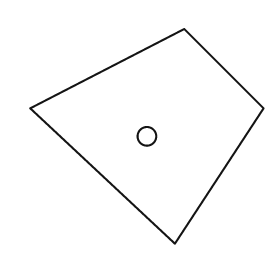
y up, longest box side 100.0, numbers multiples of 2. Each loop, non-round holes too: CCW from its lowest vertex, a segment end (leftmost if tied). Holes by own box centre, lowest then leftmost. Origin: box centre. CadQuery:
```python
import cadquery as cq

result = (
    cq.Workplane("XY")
    .moveTo(12.0, -46.0)
    .lineTo(50.0, 12.0)
    .lineTo(16.0, 46.0)
    .lineTo(-50.0, 12.0)
    .close()
    .moveTo(0.0, 0.0)
    .circle(4.0)
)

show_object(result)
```